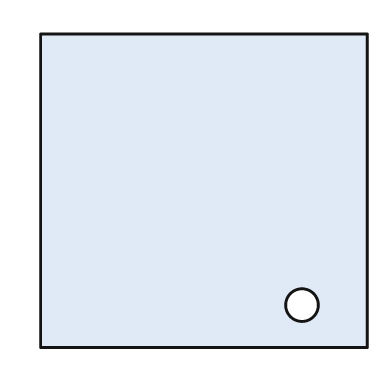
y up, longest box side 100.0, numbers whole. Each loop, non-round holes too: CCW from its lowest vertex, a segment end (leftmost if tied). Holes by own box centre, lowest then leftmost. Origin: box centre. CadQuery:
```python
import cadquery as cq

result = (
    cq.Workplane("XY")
    .moveTo(-50.0, -48.0)
    .lineTo(50.0, -48.0)
    .lineTo(50.0, 48.0)
    .lineTo(-50.0, 48.0)
    .close()
    .moveTo(30.0, -35.0)
    .circle(5.0)
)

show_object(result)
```